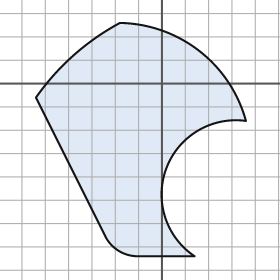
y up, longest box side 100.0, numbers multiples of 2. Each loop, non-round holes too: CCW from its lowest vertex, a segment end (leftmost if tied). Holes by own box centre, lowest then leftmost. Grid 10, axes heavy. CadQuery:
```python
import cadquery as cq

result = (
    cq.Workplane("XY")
    .moveTo(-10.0, -74.0)
    .lineTo(14.0, -74.0)
    .threePointArc((2.0, -36.0), (36.0, -16.0))
    .threePointArc((16.0, 14.0), (-18.0, 26.0))
    .threePointArc((-38.0, 12.0), (-54.0, -6.0))
    .lineTo(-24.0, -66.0)
    .threePointArc((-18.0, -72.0), (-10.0, -74.0))
    .close()
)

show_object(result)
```